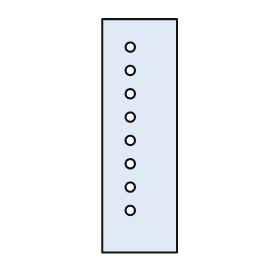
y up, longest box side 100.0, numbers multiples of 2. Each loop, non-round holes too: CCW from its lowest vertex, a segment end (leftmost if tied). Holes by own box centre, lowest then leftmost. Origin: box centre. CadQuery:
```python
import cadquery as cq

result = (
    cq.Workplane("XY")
    .moveTo(-16.0, -50.0)
    .lineTo(16.0, -50.0)
    .lineTo(16.0, 50.0)
    .lineTo(-16.0, 50.0)
    .close()
    .moveTo(-4.0, -32.0)
    .circle(2.0)
    .moveTo(-4.0, -22.0)
    .circle(2.0)
    .moveTo(-4.0, -12.0)
    .circle(2.0)
    .moveTo(-4.0, -2.0)
    .circle(2.0)
    .moveTo(-4.0, 8.0)
    .circle(2.0)
    .moveTo(-4.0, 18.0)
    .circle(2.0)
    .moveTo(-4.0, 28.0)
    .circle(2.0)
    .moveTo(-4.0, 38.0)
    .circle(2.0)
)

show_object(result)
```